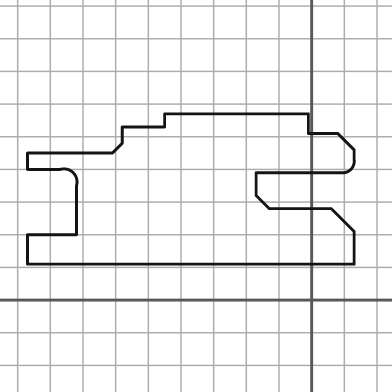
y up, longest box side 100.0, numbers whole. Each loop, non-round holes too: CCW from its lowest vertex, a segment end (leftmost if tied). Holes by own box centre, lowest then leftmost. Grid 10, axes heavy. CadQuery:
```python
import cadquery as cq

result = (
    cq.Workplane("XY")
    .moveTo(-87.0, 11.0)
    .lineTo(13.0, 11.0)
    .lineTo(13.0, 21.0)
    .lineTo(6.0, 28.0)
    .lineTo(-13.0, 28.0)
    .lineTo(-17.0, 32.0)
    .lineTo(-17.0, 39.0)
    .lineTo(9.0, 39.0)
    .threePointArc((12.0, 40.0), (13.0, 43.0))
    .lineTo(13.0, 46.0)
    .lineTo(8.0, 51.0)
    .lineTo(-1.0, 51.0)
    .lineTo(-1.0, 57.0)
    .lineTo(-45.0, 57.0)
    .lineTo(-45.0, 53.0)
    .lineTo(-58.0, 53.0)
    .lineTo(-58.0, 48.0)
    .lineTo(-61.0, 45.0)
    .lineTo(-87.0, 45.0)
    .lineTo(-87.0, 40.0)
    .lineTo(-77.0, 40.0)
    .threePointArc((-73.0, 39.0), (-72.0, 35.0))
    .lineTo(-72.0, 20.0)
    .lineTo(-87.0, 20.0)
    .close()
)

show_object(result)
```